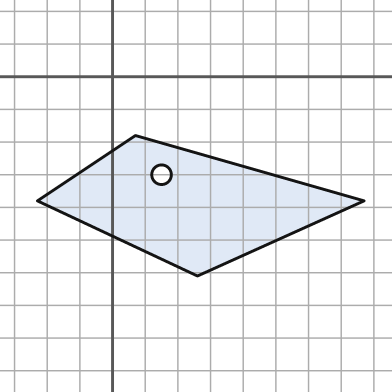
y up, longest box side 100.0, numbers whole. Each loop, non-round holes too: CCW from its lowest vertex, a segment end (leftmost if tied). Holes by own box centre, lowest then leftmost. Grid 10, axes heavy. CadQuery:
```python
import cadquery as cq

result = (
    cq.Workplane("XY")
    .moveTo(26.0, -61.0)
    .lineTo(77.0, -38.0)
    .lineTo(7.0, -18.0)
    .lineTo(-23.0, -38.0)
    .close()
    .moveTo(15.0, -30.0)
    .circle(3.0)
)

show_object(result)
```